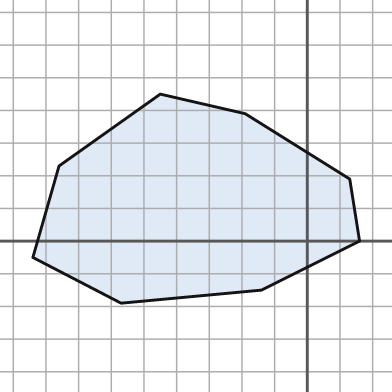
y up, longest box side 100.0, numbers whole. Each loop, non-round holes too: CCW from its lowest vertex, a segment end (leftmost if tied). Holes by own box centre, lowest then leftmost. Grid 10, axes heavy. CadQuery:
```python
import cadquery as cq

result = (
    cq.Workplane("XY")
    .moveTo(-57.0, -19.0)
    .lineTo(-14.0, -15.0)
    .lineTo(16.0, 0.0)
    .lineTo(13.0, 19.0)
    .lineTo(-19.0, 39.0)
    .lineTo(-45.0, 45.0)
    .lineTo(-76.0, 23.0)
    .lineTo(-84.0, -5.0)
    .close()
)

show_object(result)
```